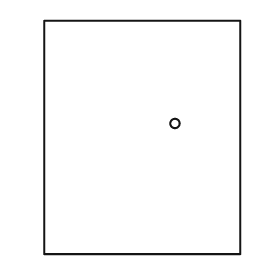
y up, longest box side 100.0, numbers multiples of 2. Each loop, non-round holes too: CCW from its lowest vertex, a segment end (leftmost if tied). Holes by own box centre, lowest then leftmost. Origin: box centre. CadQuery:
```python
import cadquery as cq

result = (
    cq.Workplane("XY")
    .moveTo(-42.0, -50.0)
    .lineTo(42.0, -50.0)
    .lineTo(42.0, 50.0)
    .lineTo(-42.0, 50.0)
    .close()
    .moveTo(14.0, 6.0)
    .circle(2.0)
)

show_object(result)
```